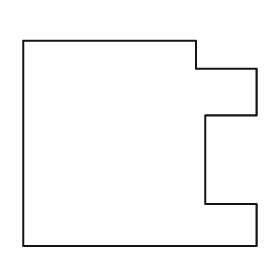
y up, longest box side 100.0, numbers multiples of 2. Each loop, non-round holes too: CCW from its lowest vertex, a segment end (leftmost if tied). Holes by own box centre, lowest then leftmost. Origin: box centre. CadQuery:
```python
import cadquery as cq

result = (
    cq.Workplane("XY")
    .moveTo(-50.0, -44.0)
    .lineTo(50.0, -44.0)
    .lineTo(50.0, -26.0)
    .lineTo(28.0, -26.0)
    .lineTo(28.0, 12.0)
    .lineTo(50.0, 12.0)
    .lineTo(50.0, 32.0)
    .lineTo(24.0, 32.0)
    .lineTo(24.0, 44.0)
    .lineTo(-50.0, 44.0)
    .close()
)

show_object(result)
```